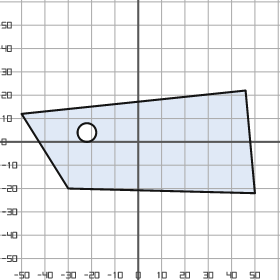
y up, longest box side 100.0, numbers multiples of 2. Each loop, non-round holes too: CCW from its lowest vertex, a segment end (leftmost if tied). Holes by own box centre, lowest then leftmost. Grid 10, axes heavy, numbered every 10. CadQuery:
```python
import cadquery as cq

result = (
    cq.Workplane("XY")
    .moveTo(50.0, -22.0)
    .lineTo(46.0, 22.0)
    .lineTo(-50.0, 12.0)
    .lineTo(-30.0, -20.0)
    .close()
    .moveTo(-22.0, 4.0)
    .circle(4.0)
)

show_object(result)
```